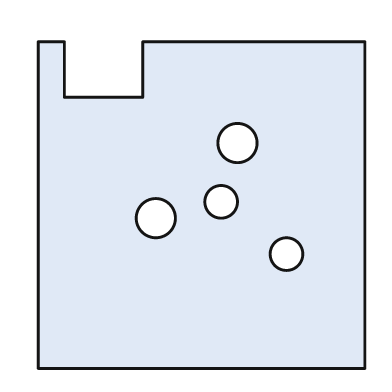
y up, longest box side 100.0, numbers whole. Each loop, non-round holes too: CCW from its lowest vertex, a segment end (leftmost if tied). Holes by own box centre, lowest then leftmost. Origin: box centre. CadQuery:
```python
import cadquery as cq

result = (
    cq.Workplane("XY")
    .moveTo(-50.0, -50.0)
    .lineTo(50.0, -50.0)
    .lineTo(50.0, 50.0)
    .lineTo(-18.0, 50.0)
    .lineTo(-18.0, 33.0)
    .lineTo(-42.0, 33.0)
    .lineTo(-42.0, 50.0)
    .lineTo(-50.0, 50.0)
    .close()
    .moveTo(26.0, -15.0)
    .circle(5.0)
    .moveTo(-14.0, -4.0)
    .circle(6.0)
    .moveTo(6.0, 1.0)
    .circle(5.0)
    .moveTo(11.0, 19.0)
    .circle(6.0)
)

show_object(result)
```